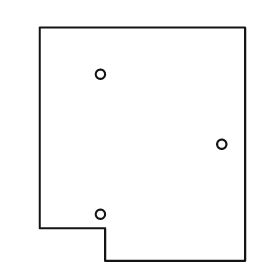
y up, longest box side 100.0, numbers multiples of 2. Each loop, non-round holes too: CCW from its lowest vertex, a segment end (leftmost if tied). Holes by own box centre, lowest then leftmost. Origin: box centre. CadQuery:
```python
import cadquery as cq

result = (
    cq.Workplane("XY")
    .moveTo(-16.0, -50.0)
    .lineTo(44.0, -50.0)
    .lineTo(44.0, 50.0)
    .lineTo(-44.0, 50.0)
    .lineTo(-44.0, -36.0)
    .lineTo(-16.0, -36.0)
    .close()
    .moveTo(-18.0, -30.0)
    .circle(2.0)
    .moveTo(34.0, 0.0)
    .circle(2.0)
    .moveTo(-18.0, 30.0)
    .circle(2.0)
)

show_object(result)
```